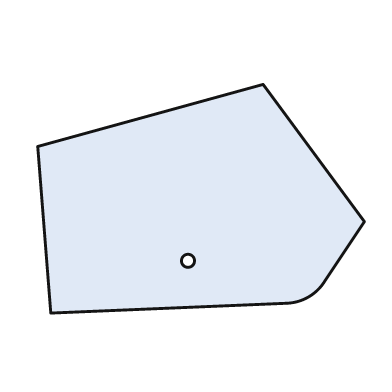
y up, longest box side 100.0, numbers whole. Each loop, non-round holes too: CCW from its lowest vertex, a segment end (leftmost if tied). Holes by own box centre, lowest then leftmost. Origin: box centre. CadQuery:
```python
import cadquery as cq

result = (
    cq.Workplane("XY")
    .moveTo(-46.0, -35.0)
    .lineTo(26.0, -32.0)
    .threePointArc((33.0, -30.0), (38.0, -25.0))
    .lineTo(50.0, -7.0)
    .lineTo(19.0, 35.0)
    .lineTo(-50.0, 16.0)
    .close()
    .moveTo(-4.0, -19.0)
    .circle(2.0)
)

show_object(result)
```